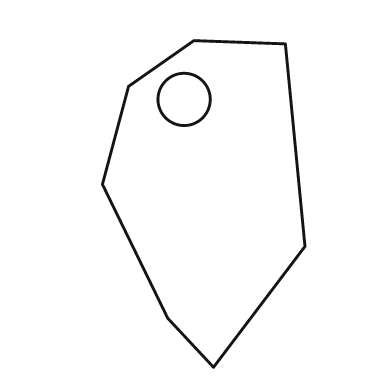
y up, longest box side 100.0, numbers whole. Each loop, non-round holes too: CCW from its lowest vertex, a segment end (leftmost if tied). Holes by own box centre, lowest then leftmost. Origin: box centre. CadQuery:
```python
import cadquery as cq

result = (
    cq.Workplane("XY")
    .moveTo(3.0, -50.0)
    .lineTo(31.0, -13.0)
    .lineTo(25.0, 49.0)
    .lineTo(-3.0, 50.0)
    .lineTo(-23.0, 36.0)
    .lineTo(-31.0, 6.0)
    .lineTo(-11.0, -35.0)
    .close()
    .moveTo(-6.0, 32.0)
    .circle(8.0)
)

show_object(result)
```